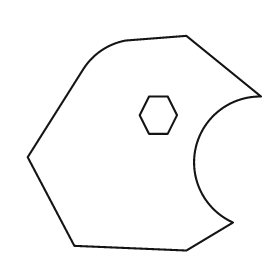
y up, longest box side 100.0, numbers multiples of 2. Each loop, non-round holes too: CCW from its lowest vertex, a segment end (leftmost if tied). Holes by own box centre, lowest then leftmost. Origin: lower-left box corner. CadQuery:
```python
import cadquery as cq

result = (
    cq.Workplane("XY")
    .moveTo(68.0, 0.0)
    .lineTo(88.0, 12.0)
    .threePointArc((72.0, 44.0), (100.0, 66.0))
    .lineTo(68.0, 92.0)
    .lineTo(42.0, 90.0)
    .threePointArc((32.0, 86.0), (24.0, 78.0))
    .lineTo(0.0, 40.0)
    .lineTo(20.0, 2.0)
    .close()
    .moveTo(52.0, 50.0)
    .lineTo(60.0, 50.0)
    .lineTo(64.0, 58.0)
    .lineTo(60.0, 66.0)
    .lineTo(52.0, 66.0)
    .lineTo(48.0, 58.0)
    .close()
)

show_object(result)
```